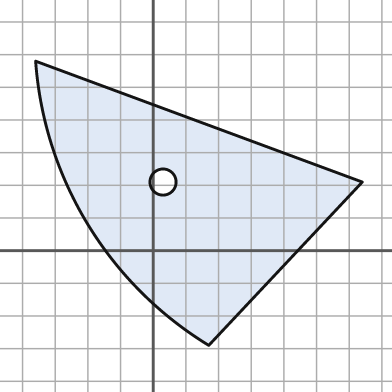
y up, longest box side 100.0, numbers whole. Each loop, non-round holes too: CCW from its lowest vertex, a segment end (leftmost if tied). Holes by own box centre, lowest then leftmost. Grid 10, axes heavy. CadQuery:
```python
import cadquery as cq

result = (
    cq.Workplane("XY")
    .moveTo(17.0, -29.0)
    .lineTo(64.0, 21.0)
    .lineTo(-36.0, 58.0)
    .threePointArc((-20.0, 8.0), (17.0, -29.0))
    .close()
    .moveTo(3.0, 21.0)
    .circle(4.0)
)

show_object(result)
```